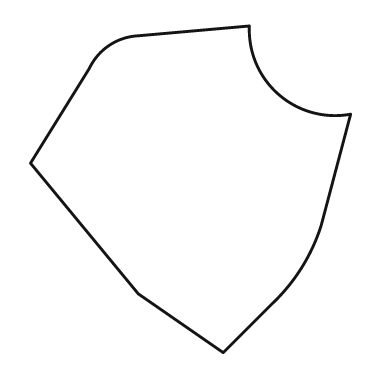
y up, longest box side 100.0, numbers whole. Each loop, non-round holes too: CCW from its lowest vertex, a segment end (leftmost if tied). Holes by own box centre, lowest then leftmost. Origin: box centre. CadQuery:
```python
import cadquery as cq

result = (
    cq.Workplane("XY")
    .moveTo(10.0, -50.0)
    .lineTo(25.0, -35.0)
    .threePointArc((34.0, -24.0), (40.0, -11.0))
    .lineTo(49.0, 23.0)
    .threePointArc((27.0, 29.0), (18.0, 50.0))
    .lineTo(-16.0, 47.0)
    .threePointArc((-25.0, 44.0), (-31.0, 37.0))
    .lineTo(-49.0, 8.0)
    .lineTo(-16.0, -32.0)
    .close()
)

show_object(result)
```